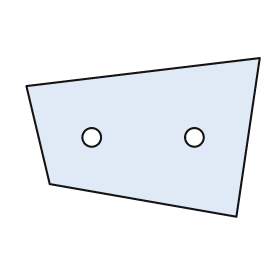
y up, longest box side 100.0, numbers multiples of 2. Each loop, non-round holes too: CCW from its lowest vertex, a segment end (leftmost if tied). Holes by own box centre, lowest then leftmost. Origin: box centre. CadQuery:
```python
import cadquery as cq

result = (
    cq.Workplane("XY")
    .moveTo(40.0, -34.0)
    .lineTo(50.0, 34.0)
    .lineTo(-50.0, 22.0)
    .lineTo(-40.0, -20.0)
    .close()
    .moveTo(-22.0, 0.0)
    .circle(4.0)
    .moveTo(22.0, 0.0)
    .circle(4.0)
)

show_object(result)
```